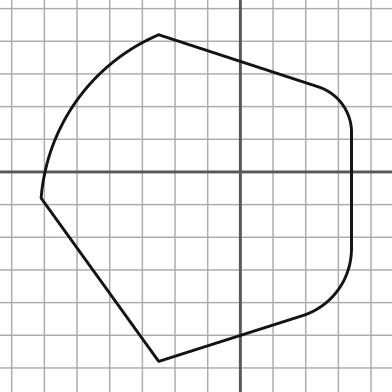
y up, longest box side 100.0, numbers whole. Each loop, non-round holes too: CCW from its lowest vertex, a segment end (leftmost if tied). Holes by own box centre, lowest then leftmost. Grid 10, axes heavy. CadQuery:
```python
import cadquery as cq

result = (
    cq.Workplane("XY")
    .moveTo(-25.0, -58.0)
    .lineTo(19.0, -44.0)
    .threePointArc((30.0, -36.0), (34.0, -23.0))
    .lineTo(34.0, 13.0)
    .threePointArc((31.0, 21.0), (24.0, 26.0))
    .lineTo(-25.0, 42.0)
    .threePointArc((-50.0, 22.0), (-61.0, -8.0))
    .close()
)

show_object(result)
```